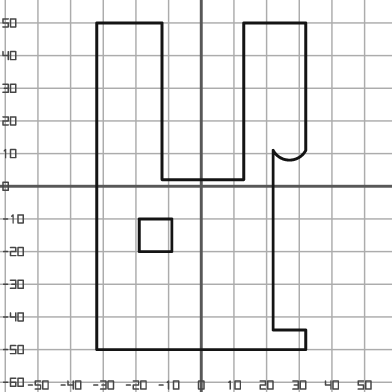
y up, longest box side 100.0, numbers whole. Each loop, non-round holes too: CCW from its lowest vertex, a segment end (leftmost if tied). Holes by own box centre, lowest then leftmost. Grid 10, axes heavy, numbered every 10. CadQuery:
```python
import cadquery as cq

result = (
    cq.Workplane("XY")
    .moveTo(-32.0, -50.0)
    .lineTo(32.0, -50.0)
    .lineTo(32.0, -44.0)
    .lineTo(22.0, -44.0)
    .lineTo(22.0, 11.0)
    .threePointArc((27.0, 8.0), (32.0, 11.0))
    .lineTo(32.0, 50.0)
    .lineTo(13.0, 50.0)
    .lineTo(13.0, 2.0)
    .lineTo(-12.0, 2.0)
    .lineTo(-12.0, 50.0)
    .lineTo(-32.0, 50.0)
    .close()
    .moveTo(-19.0, -20.0)
    .lineTo(-9.0, -20.0)
    .lineTo(-9.0, -10.0)
    .lineTo(-19.0, -10.0)
    .close()
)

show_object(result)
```